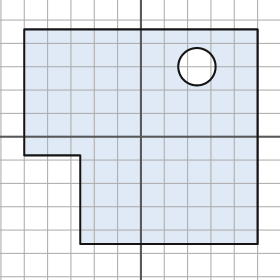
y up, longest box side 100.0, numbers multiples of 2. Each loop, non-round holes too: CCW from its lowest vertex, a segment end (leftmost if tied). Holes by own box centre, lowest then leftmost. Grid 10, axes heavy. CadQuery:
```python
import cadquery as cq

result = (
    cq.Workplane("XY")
    .moveTo(-26.0, -46.0)
    .lineTo(50.0, -46.0)
    .lineTo(50.0, 46.0)
    .lineTo(-50.0, 46.0)
    .lineTo(-50.0, -8.0)
    .lineTo(-26.0, -8.0)
    .close()
    .moveTo(24.0, 30.0)
    .circle(8.0)
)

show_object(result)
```